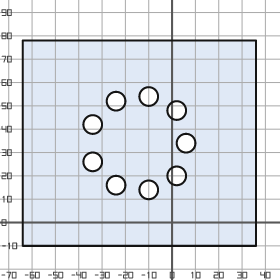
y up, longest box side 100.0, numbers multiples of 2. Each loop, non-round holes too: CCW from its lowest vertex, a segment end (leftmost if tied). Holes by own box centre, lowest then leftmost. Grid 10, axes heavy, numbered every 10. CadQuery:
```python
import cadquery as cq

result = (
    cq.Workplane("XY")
    .moveTo(-64.0, -10.0)
    .lineTo(36.0, -10.0)
    .lineTo(36.0, 78.0)
    .lineTo(-64.0, 78.0)
    .close()
    .moveTo(-10.0, 14.0)
    .circle(4.0)
    .moveTo(-24.0, 16.0)
    .circle(4.0)
    .moveTo(2.0, 20.0)
    .circle(4.0)
    .moveTo(-34.0, 26.0)
    .circle(4.0)
    .moveTo(6.0, 34.0)
    .circle(4.0)
    .moveTo(-34.0, 42.0)
    .circle(4.0)
    .moveTo(2.0, 48.0)
    .circle(4.0)
    .moveTo(-24.0, 52.0)
    .circle(4.0)
    .moveTo(-10.0, 54.0)
    .circle(4.0)
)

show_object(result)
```